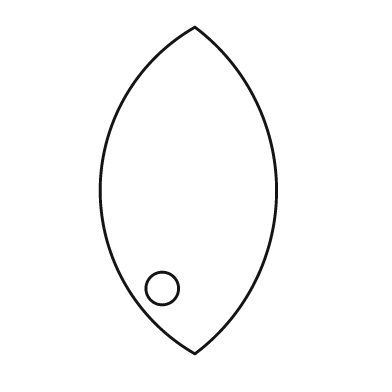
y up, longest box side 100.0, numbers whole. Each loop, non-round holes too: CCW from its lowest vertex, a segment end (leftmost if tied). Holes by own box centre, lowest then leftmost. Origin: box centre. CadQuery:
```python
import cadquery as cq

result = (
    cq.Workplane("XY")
    .moveTo(2.0, -50.0)
    .threePointArc((27.0, 0.0), (2.0, 50.0))
    .threePointArc((-27.0, 0.0), (2.0, -50.0))
    .close()
    .moveTo(-8.0, -30.0)
    .circle(5.0)
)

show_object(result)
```